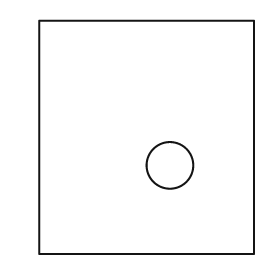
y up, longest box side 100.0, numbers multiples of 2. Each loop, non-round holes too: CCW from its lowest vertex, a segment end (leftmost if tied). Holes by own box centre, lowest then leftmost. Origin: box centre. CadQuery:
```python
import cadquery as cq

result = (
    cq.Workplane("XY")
    .moveTo(-46.0, -50.0)
    .lineTo(46.0, -50.0)
    .lineTo(46.0, 50.0)
    .lineTo(-46.0, 50.0)
    .close()
    .moveTo(10.0, -12.0)
    .circle(10.0)
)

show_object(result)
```